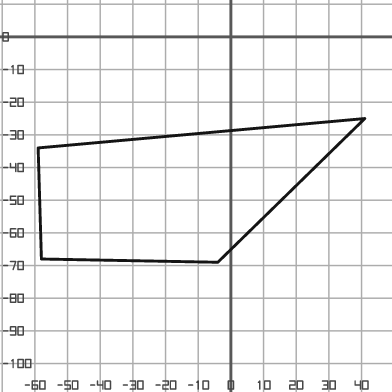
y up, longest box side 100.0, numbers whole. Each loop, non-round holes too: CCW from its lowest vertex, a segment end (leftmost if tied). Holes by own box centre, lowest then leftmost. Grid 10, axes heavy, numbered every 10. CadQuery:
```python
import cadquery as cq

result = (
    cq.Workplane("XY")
    .moveTo(-4.0, -69.0)
    .lineTo(41.0, -25.0)
    .lineTo(-59.0, -34.0)
    .lineTo(-58.0, -68.0)
    .close()
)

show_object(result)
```